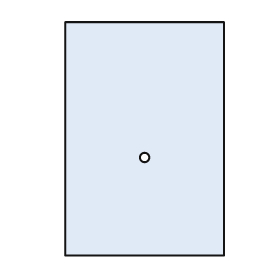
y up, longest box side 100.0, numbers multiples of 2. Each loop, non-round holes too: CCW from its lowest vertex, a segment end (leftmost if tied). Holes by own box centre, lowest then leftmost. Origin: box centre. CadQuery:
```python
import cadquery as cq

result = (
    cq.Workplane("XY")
    .moveTo(-34.0, -50.0)
    .lineTo(34.0, -50.0)
    .lineTo(34.0, 50.0)
    .lineTo(-34.0, 50.0)
    .close()
    .moveTo(0.0, -8.0)
    .circle(2.0)
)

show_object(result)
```